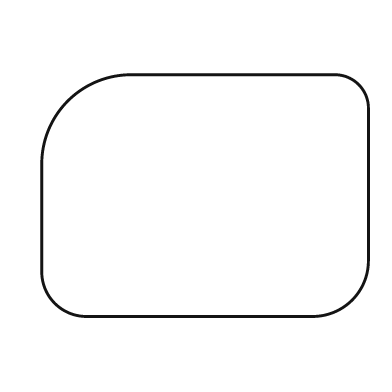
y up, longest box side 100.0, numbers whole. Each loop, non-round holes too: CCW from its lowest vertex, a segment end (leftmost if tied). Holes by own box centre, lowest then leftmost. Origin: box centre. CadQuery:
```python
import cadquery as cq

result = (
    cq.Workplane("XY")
    .moveTo(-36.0, -37.0)
    .lineTo(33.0, -37.0)
    .threePointArc((45.0, -32.0), (50.0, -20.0))
    .lineTo(50.0, 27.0)
    .threePointArc((47.0, 34.0), (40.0, 37.0))
    .lineTo(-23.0, 37.0)
    .threePointArc((-42.0, 29.0), (-50.0, 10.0))
    .lineTo(-50.0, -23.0)
    .threePointArc((-46.0, -33.0), (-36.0, -37.0))
    .close()
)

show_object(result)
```